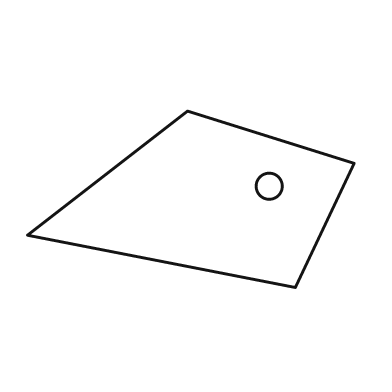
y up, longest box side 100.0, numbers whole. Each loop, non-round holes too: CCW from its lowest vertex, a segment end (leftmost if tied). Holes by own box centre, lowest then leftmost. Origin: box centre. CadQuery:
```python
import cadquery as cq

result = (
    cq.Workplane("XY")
    .moveTo(32.0, -27.0)
    .lineTo(50.0, 11.0)
    .lineTo(-1.0, 27.0)
    .lineTo(-50.0, -11.0)
    .close()
    .moveTo(24.0, 4.0)
    .circle(4.0)
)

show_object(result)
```